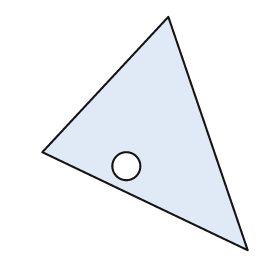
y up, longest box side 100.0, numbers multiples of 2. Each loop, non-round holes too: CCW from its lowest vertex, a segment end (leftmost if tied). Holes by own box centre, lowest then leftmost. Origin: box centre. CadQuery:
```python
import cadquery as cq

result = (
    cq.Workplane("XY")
    .moveTo(44.0, -50.0)
    .lineTo(10.0, 50.0)
    .lineTo(-44.0, -8.0)
    .close()
    .moveTo(-8.0, -14.0)
    .circle(6.0)
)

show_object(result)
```